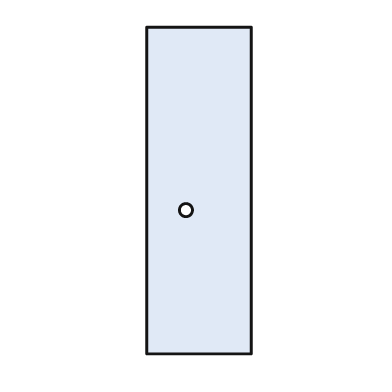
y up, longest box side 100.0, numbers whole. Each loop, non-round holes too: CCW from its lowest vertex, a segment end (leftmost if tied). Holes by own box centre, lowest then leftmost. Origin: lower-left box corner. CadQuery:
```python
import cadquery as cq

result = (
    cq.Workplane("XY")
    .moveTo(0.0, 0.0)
    .lineTo(32.0, 0.0)
    .lineTo(32.0, 100.0)
    .lineTo(0.0, 100.0)
    .close()
    .moveTo(12.0, 44.0)
    .circle(2.0)
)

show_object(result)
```